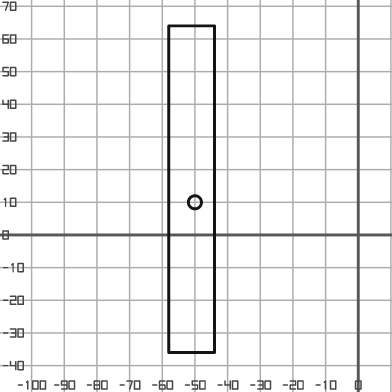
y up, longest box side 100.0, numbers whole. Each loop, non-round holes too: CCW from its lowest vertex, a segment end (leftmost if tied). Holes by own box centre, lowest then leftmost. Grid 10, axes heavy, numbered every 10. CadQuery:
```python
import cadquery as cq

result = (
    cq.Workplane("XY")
    .moveTo(-58.0, -36.0)
    .lineTo(-44.0, -36.0)
    .lineTo(-44.0, 64.0)
    .lineTo(-58.0, 64.0)
    .close()
    .moveTo(-50.0, 10.0)
    .circle(2.0)
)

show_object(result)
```